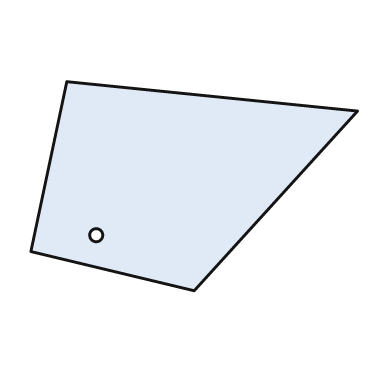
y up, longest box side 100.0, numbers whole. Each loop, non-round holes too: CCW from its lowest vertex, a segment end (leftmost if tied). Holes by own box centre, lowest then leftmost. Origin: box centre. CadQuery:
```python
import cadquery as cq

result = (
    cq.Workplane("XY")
    .moveTo(0.0, -32.0)
    .lineTo(50.0, 23.0)
    .lineTo(-39.0, 32.0)
    .lineTo(-50.0, -20.0)
    .close()
    .moveTo(-30.0, -15.0)
    .circle(2.0)
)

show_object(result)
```